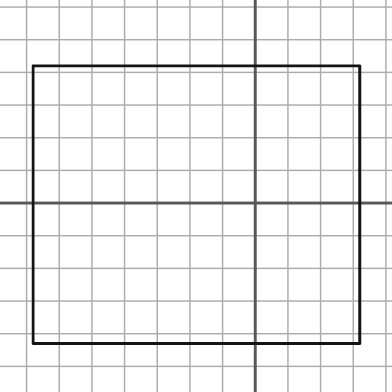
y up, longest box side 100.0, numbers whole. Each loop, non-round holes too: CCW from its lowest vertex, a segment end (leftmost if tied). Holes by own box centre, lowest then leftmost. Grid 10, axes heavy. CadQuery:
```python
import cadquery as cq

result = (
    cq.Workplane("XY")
    .moveTo(-68.0, -43.0)
    .lineTo(32.0, -43.0)
    .lineTo(32.0, 42.0)
    .lineTo(-68.0, 42.0)
    .close()
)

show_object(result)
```